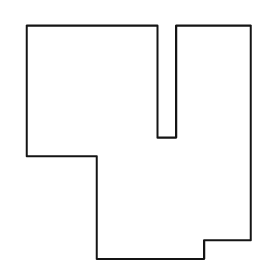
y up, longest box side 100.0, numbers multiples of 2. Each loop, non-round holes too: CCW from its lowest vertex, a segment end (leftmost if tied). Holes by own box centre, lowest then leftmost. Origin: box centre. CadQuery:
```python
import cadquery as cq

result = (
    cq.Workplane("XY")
    .moveTo(-18.0, -50.0)
    .lineTo(28.0, -50.0)
    .lineTo(28.0, -42.0)
    .lineTo(48.0, -42.0)
    .lineTo(48.0, 50.0)
    .lineTo(16.0, 50.0)
    .lineTo(16.0, 2.0)
    .lineTo(8.0, 2.0)
    .lineTo(8.0, 50.0)
    .lineTo(-48.0, 50.0)
    .lineTo(-48.0, -6.0)
    .lineTo(-18.0, -6.0)
    .close()
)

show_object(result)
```